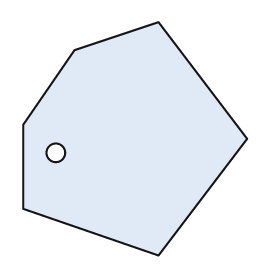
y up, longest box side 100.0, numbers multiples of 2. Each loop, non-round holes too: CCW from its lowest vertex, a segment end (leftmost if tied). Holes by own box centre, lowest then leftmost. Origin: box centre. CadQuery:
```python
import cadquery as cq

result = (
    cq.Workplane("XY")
    .moveTo(10.0, -50.0)
    .lineTo(48.0, 0.0)
    .lineTo(10.0, 50.0)
    .lineTo(-26.0, 38.0)
    .lineTo(-48.0, 6.0)
    .lineTo(-48.0, -30.0)
    .close()
    .moveTo(-34.0, -6.0)
    .circle(4.0)
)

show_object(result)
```